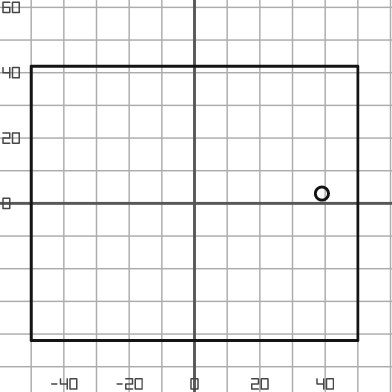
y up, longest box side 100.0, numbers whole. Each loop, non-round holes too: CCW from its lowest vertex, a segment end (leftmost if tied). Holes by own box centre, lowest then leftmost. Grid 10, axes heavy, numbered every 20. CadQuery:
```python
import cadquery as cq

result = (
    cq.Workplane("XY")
    .moveTo(-50.0, -42.0)
    .lineTo(50.0, -42.0)
    .lineTo(50.0, 42.0)
    .lineTo(-50.0, 42.0)
    .close()
    .moveTo(39.0, 3.0)
    .circle(2.0)
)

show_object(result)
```